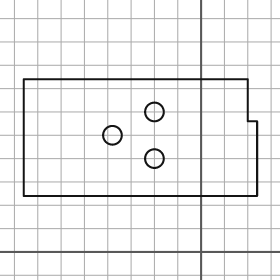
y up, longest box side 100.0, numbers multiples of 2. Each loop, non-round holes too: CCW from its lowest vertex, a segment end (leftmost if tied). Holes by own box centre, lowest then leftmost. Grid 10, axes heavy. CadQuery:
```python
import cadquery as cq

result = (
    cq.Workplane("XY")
    .moveTo(-76.0, 24.0)
    .lineTo(24.0, 24.0)
    .lineTo(24.0, 56.0)
    .lineTo(20.0, 56.0)
    .lineTo(20.0, 74.0)
    .lineTo(-76.0, 74.0)
    .close()
    .moveTo(-20.0, 40.0)
    .circle(4.0)
    .moveTo(-38.0, 50.0)
    .circle(4.0)
    .moveTo(-20.0, 60.0)
    .circle(4.0)
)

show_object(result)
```